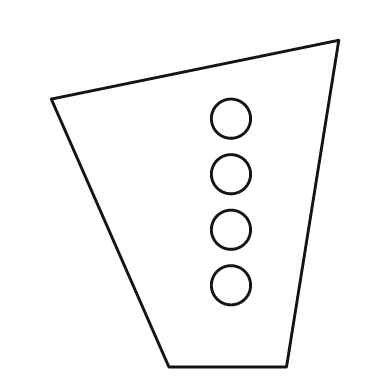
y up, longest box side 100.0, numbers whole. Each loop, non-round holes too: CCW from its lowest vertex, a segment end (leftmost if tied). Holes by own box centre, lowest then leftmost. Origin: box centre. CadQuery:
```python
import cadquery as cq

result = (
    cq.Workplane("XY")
    .moveTo(-8.0, -50.0)
    .lineTo(28.0, -50.0)
    .lineTo(44.0, 50.0)
    .lineTo(-44.0, 32.0)
    .close()
    .moveTo(11.0, -25.0)
    .circle(6.0)
    .moveTo(11.0, -8.0)
    .circle(6.0)
    .moveTo(11.0, 9.0)
    .circle(6.0)
    .moveTo(11.0, 26.0)
    .circle(6.0)
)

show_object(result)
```